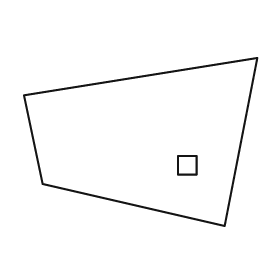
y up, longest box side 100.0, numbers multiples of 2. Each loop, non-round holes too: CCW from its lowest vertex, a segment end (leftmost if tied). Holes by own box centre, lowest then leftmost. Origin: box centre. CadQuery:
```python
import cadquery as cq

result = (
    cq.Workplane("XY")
    .moveTo(36.0, -36.0)
    .lineTo(50.0, 36.0)
    .lineTo(-50.0, 20.0)
    .lineTo(-42.0, -18.0)
    .close()
    .moveTo(16.0, -14.0)
    .lineTo(24.0, -14.0)
    .lineTo(24.0, -6.0)
    .lineTo(16.0, -6.0)
    .close()
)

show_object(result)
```